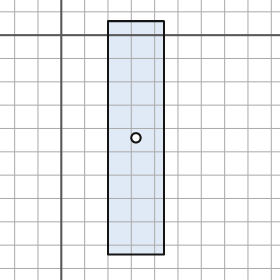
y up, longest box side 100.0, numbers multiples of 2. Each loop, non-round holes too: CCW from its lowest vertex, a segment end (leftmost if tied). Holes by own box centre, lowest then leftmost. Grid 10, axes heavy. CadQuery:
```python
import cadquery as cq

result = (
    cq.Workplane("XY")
    .moveTo(20.0, -94.0)
    .lineTo(44.0, -94.0)
    .lineTo(44.0, 6.0)
    .lineTo(20.0, 6.0)
    .close()
    .moveTo(32.0, -44.0)
    .circle(2.0)
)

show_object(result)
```